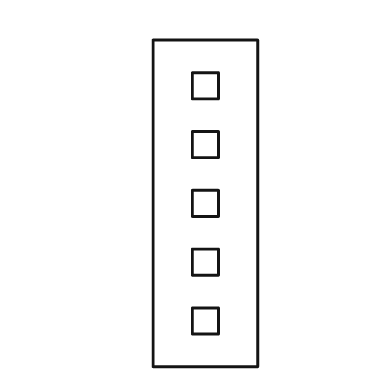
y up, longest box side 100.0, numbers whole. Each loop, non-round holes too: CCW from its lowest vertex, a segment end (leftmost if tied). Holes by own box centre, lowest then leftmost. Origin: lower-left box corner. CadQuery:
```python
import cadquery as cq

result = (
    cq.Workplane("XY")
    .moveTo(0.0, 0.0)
    .lineTo(32.0, 0.0)
    .lineTo(32.0, 100.0)
    .lineTo(0.0, 100.0)
    .close()
    .moveTo(12.0, 10.0)
    .lineTo(20.0, 10.0)
    .lineTo(20.0, 18.0)
    .lineTo(12.0, 18.0)
    .close()
    .moveTo(12.0, 28.0)
    .lineTo(20.0, 28.0)
    .lineTo(20.0, 36.0)
    .lineTo(12.0, 36.0)
    .close()
    .moveTo(12.0, 46.0)
    .lineTo(20.0, 46.0)
    .lineTo(20.0, 54.0)
    .lineTo(12.0, 54.0)
    .close()
    .moveTo(12.0, 64.0)
    .lineTo(20.0, 64.0)
    .lineTo(20.0, 72.0)
    .lineTo(12.0, 72.0)
    .close()
    .moveTo(12.0, 82.0)
    .lineTo(20.0, 82.0)
    .lineTo(20.0, 90.0)
    .lineTo(12.0, 90.0)
    .close()
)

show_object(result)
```